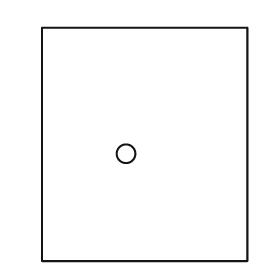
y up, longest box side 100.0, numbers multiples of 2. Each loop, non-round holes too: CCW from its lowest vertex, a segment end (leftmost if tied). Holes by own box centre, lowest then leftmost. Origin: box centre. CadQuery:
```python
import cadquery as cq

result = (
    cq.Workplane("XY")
    .moveTo(-44.0, -50.0)
    .lineTo(44.0, -50.0)
    .lineTo(44.0, 50.0)
    .lineTo(-44.0, 50.0)
    .close()
    .moveTo(-8.0, -4.0)
    .circle(4.0)
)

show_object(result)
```